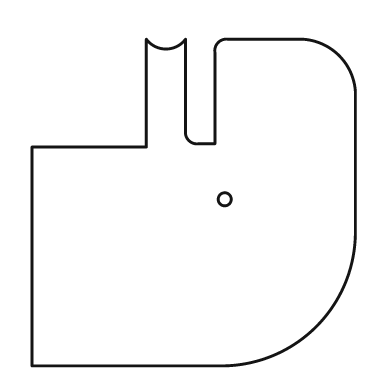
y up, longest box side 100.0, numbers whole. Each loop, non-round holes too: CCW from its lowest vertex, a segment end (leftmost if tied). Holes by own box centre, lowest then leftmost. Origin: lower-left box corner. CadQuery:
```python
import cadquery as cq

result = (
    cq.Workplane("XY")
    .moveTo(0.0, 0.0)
    .lineTo(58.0, 0.0)
    .threePointArc((87.0, 12.0), (99.0, 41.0))
    .lineTo(99.0, 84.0)
    .threePointArc((94.0, 95.0), (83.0, 100.0))
    .lineTo(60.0, 100.0)
    .threePointArc((57.0, 99.0), (56.0, 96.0))
    .lineTo(56.0, 68.0)
    .lineTo(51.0, 68.0)
    .threePointArc((48.0, 69.0), (47.0, 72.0))
    .lineTo(47.0, 100.0)
    .threePointArc((41.0, 97.0), (35.0, 100.0))
    .lineTo(35.0, 67.0)
    .lineTo(0.0, 67.0)
    .close()
    .moveTo(59.0, 51.0)
    .circle(2.0)
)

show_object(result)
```